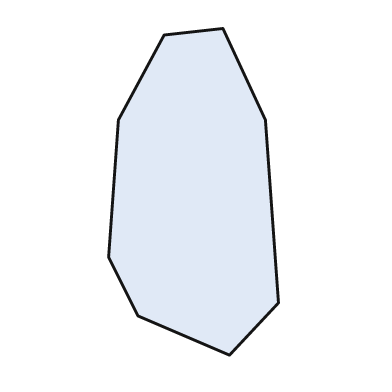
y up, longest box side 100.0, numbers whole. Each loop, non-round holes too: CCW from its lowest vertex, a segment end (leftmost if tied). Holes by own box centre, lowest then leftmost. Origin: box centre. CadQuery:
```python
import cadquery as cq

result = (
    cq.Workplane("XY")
    .moveTo(11.0, -50.0)
    .lineTo(26.0, -34.0)
    .lineTo(22.0, 22.0)
    .lineTo(9.0, 50.0)
    .lineTo(-9.0, 48.0)
    .lineTo(-23.0, 22.0)
    .lineTo(-26.0, -20.0)
    .lineTo(-17.0, -38.0)
    .close()
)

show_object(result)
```